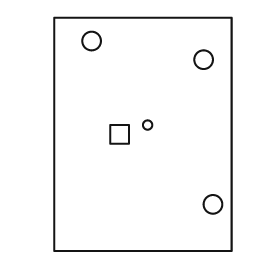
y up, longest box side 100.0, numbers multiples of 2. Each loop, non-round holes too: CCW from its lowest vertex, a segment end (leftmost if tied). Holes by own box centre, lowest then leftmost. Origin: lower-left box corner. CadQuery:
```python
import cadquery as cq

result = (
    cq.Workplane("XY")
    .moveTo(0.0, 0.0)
    .lineTo(76.0, 0.0)
    .lineTo(76.0, 100.0)
    .lineTo(0.0, 100.0)
    .close()
    .moveTo(68.0, 20.0)
    .circle(4.0)
    .moveTo(24.0, 46.0)
    .lineTo(32.0, 46.0)
    .lineTo(32.0, 54.0)
    .lineTo(24.0, 54.0)
    .close()
    .moveTo(40.0, 54.0)
    .circle(2.0)
    .moveTo(64.0, 82.0)
    .circle(4.0)
    .moveTo(16.0, 90.0)
    .circle(4.0)
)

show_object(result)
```